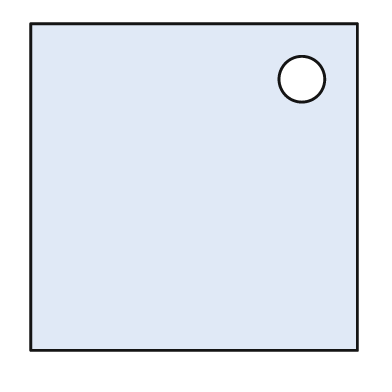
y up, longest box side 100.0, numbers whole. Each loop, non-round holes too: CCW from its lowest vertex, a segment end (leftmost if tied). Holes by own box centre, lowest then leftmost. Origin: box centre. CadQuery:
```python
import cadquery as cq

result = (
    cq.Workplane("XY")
    .moveTo(-50.0, -50.0)
    .lineTo(50.0, -50.0)
    .lineTo(50.0, 50.0)
    .lineTo(-50.0, 50.0)
    .close()
    .moveTo(33.0, 33.0)
    .circle(7.0)
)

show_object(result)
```